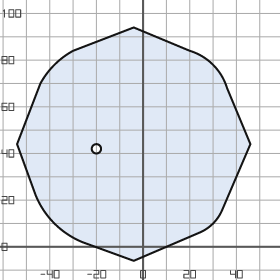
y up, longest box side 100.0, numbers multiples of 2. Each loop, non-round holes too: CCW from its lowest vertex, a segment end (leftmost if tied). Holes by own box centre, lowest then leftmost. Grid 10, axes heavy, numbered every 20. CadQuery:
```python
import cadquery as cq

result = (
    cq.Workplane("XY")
    .moveTo(-4.0, -6.0)
    .lineTo(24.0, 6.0)
    .threePointArc((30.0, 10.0), (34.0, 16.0))
    .lineTo(46.0, 44.0)
    .lineTo(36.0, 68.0)
    .threePointArc((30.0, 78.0), (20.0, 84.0))
    .lineTo(-4.0, 94.0)
    .lineTo(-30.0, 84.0)
    .threePointArc((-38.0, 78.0), (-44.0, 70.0))
    .lineTo(-54.0, 44.0)
    .lineTo(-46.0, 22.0)
    .threePointArc((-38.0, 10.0), (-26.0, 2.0))
    .close()
    .moveTo(-20.0, 42.0)
    .circle(2.0)
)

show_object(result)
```